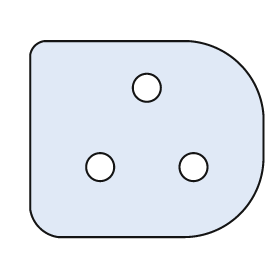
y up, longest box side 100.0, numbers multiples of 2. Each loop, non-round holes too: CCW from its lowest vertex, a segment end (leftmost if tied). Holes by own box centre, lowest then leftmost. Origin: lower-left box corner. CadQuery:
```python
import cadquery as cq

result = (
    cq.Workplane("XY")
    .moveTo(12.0, 0.0)
    .lineTo(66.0, 0.0)
    .threePointArc((90.0, 10.0), (100.0, 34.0))
    .lineTo(100.0, 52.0)
    .threePointArc((90.0, 74.0), (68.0, 84.0))
    .lineTo(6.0, 84.0)
    .threePointArc((2.0, 82.0), (0.0, 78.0))
    .lineTo(0.0, 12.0)
    .threePointArc((4.0, 4.0), (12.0, 0.0))
    .close()
    .moveTo(30.0, 30.0)
    .circle(6.0)
    .moveTo(70.0, 30.0)
    .circle(6.0)
    .moveTo(50.0, 64.0)
    .circle(6.0)
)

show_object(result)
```